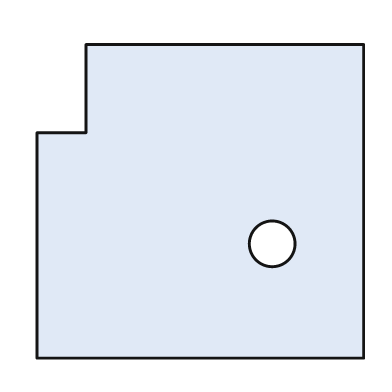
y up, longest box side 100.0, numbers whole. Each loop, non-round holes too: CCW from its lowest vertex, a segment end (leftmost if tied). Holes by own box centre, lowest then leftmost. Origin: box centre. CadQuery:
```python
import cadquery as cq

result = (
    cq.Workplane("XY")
    .moveTo(-50.0, -48.0)
    .lineTo(50.0, -48.0)
    .lineTo(50.0, 48.0)
    .lineTo(-35.0, 48.0)
    .lineTo(-35.0, 21.0)
    .lineTo(-50.0, 21.0)
    .close()
    .moveTo(22.0, -13.0)
    .circle(7.0)
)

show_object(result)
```